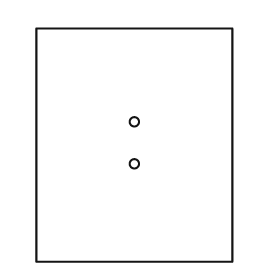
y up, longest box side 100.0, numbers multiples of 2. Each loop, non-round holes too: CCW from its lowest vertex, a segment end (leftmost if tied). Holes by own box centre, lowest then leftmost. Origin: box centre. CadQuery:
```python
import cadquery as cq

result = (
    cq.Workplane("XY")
    .moveTo(-42.0, -50.0)
    .lineTo(42.0, -50.0)
    .lineTo(42.0, 50.0)
    .lineTo(-42.0, 50.0)
    .close()
    .moveTo(0.0, -8.0)
    .circle(2.0)
    .moveTo(0.0, 10.0)
    .circle(2.0)
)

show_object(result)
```